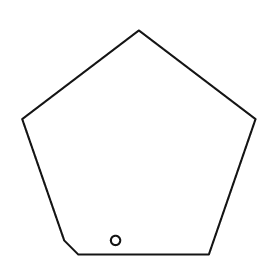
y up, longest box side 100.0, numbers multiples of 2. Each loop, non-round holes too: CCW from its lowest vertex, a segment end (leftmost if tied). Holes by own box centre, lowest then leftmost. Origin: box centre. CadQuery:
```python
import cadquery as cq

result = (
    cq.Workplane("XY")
    .moveTo(-26.0, -48.0)
    .lineTo(30.0, -48.0)
    .lineTo(50.0, 10.0)
    .lineTo(0.0, 48.0)
    .lineTo(-50.0, 10.0)
    .lineTo(-32.0, -42.0)
    .close()
    .moveTo(-10.0, -42.0)
    .circle(2.0)
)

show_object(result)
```